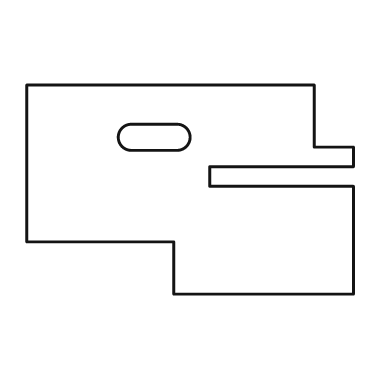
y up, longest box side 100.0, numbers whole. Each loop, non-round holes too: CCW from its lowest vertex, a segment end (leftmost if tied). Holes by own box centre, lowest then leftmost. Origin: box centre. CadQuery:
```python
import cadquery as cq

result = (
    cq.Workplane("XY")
    .moveTo(-5.0, -32.0)
    .lineTo(50.0, -32.0)
    .lineTo(50.0, 1.0)
    .lineTo(6.0, 1.0)
    .lineTo(6.0, 7.0)
    .lineTo(50.0, 7.0)
    .lineTo(50.0, 13.0)
    .lineTo(38.0, 13.0)
    .lineTo(38.0, 32.0)
    .lineTo(-50.0, 32.0)
    .lineTo(-50.0, -16.0)
    .lineTo(-5.0, -16.0)
    .close()
    .moveTo(-18.0, 12.0)
    .lineTo(-4.0, 12.0)
    .threePointArc((0.0, 16.0), (-4.0, 20.0))
    .lineTo(-18.0, 20.0)
    .threePointArc((-22.0, 16.0), (-18.0, 12.0))
    .close()
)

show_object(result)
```